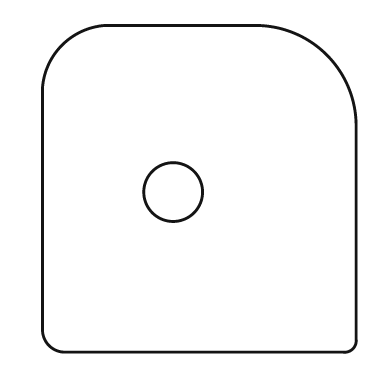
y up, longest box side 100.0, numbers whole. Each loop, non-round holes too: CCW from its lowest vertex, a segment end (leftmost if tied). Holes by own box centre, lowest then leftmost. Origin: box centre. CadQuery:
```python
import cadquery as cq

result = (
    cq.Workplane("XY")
    .moveTo(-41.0, -50.0)
    .lineTo(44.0, -50.0)
    .threePointArc((47.0, -49.0), (48.0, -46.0))
    .lineTo(48.0, 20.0)
    .threePointArc((39.0, 41.0), (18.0, 50.0))
    .lineTo(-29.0, 50.0)
    .threePointArc((-42.0, 44.0), (-48.0, 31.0))
    .lineTo(-48.0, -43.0)
    .threePointArc((-46.0, -48.0), (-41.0, -50.0))
    .close()
    .moveTo(-8.0, -1.0)
    .circle(9.0)
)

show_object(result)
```